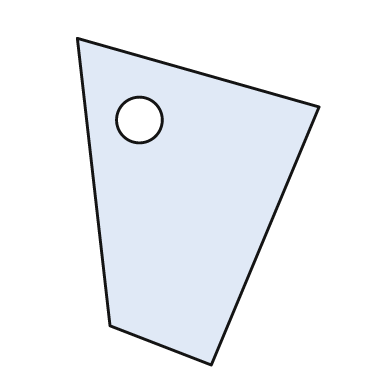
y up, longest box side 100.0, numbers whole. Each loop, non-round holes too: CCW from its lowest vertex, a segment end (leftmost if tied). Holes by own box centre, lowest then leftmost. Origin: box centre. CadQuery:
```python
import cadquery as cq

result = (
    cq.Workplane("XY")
    .moveTo(4.0, -50.0)
    .lineTo(37.0, 29.0)
    .lineTo(-37.0, 50.0)
    .lineTo(-27.0, -38.0)
    .close()
    .moveTo(-18.0, 25.0)
    .circle(7.0)
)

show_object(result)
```